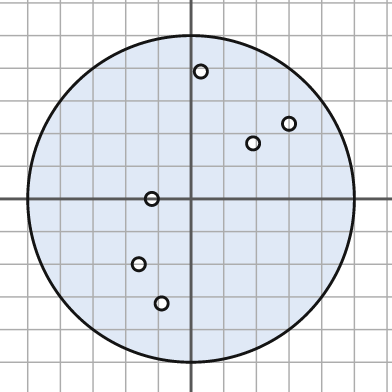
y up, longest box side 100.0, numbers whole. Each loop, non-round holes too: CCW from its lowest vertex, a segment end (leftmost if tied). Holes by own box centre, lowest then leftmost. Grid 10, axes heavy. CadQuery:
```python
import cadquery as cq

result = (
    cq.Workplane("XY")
    .moveTo(0.0, 0.0)
    .circle(50.0)
    .moveTo(-9.0, -32.0)
    .circle(2.0)
    .moveTo(-16.0, -20.0)
    .circle(2.0)
    .moveTo(-12.0, 0.0)
    .circle(2.0)
    .moveTo(19.0, 17.0)
    .circle(2.0)
    .moveTo(30.0, 23.0)
    .circle(2.0)
    .moveTo(3.0, 39.0)
    .circle(2.0)
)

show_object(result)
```